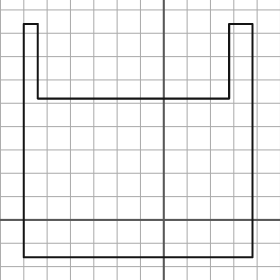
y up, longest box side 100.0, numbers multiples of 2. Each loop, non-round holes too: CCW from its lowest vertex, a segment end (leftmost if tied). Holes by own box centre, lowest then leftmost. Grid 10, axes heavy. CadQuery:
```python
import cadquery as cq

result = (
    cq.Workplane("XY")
    .moveTo(-60.0, -16.0)
    .lineTo(38.0, -16.0)
    .lineTo(38.0, 84.0)
    .lineTo(28.0, 84.0)
    .lineTo(28.0, 52.0)
    .lineTo(-54.0, 52.0)
    .lineTo(-54.0, 84.0)
    .lineTo(-60.0, 84.0)
    .close()
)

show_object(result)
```